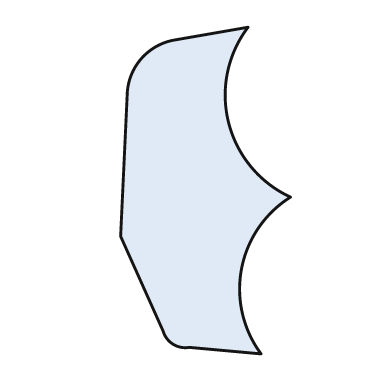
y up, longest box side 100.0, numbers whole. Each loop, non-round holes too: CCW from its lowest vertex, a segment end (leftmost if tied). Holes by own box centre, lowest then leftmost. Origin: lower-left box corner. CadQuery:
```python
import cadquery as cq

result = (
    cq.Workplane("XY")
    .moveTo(43.0, 0.0)
    .threePointArc((37.0, 26.0), (52.0, 48.0))
    .threePointArc((33.0, 71.0), (39.0, 100.0))
    .lineTo(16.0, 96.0)
    .threePointArc((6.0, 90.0), (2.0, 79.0))
    .lineTo(0.0, 36.0)
    .lineTo(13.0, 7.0)
    .threePointArc((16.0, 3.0), (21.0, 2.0))
    .close()
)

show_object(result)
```